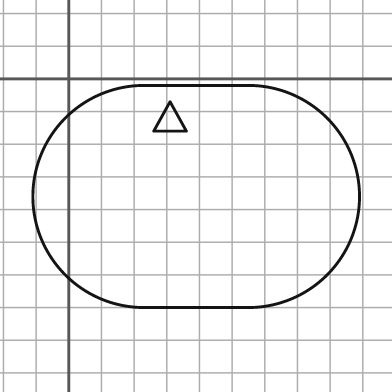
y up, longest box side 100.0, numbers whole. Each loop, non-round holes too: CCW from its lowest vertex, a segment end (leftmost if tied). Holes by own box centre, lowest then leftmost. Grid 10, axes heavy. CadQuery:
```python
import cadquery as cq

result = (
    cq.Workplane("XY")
    .moveTo(23.0, -70.0)
    .lineTo(55.0, -70.0)
    .threePointArc((89.0, -36.0), (55.0, -2.0))
    .lineTo(23.0, -2.0)
    .threePointArc((-11.0, -36.0), (23.0, -70.0))
    .close()
    .moveTo(26.0, -16.0)
    .lineTo(36.0, -16.0)
    .lineTo(31.0, -7.0)
    .close()
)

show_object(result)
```